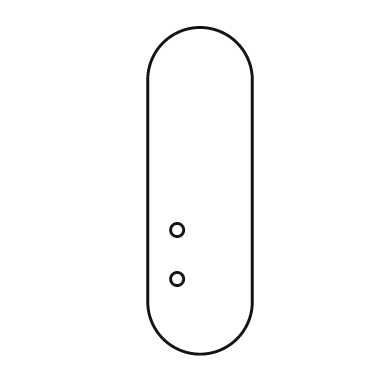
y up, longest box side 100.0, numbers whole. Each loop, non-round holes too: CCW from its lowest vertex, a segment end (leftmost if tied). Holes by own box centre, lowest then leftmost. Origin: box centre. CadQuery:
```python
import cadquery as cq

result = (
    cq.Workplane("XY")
    .moveTo(-16.0, -34.0)
    .threePointArc((0.0, -50.0), (16.0, -34.0))
    .lineTo(16.0, 34.0)
    .threePointArc((0.0, 50.0), (-16.0, 34.0))
    .close()
    .moveTo(-7.0, -27.0)
    .circle(2.0)
    .moveTo(-7.0, -12.0)
    .circle(2.0)
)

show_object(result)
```